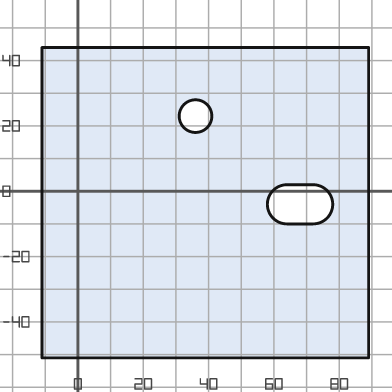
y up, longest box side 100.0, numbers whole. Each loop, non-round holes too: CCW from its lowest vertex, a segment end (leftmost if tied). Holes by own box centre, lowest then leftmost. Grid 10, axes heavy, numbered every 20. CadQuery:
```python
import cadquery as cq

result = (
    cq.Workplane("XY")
    .moveTo(-11.0, -51.0)
    .lineTo(89.0, -51.0)
    .lineTo(89.0, 44.0)
    .lineTo(-11.0, 44.0)
    .close()
    .moveTo(64.0, -10.0)
    .lineTo(72.0, -10.0)
    .threePointArc((78.0, -4.0), (72.0, 2.0))
    .lineTo(64.0, 2.0)
    .threePointArc((58.0, -4.0), (64.0, -10.0))
    .close()
    .moveTo(36.0, 23.0)
    .circle(5.0)
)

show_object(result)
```